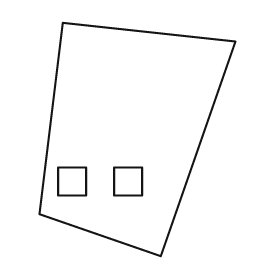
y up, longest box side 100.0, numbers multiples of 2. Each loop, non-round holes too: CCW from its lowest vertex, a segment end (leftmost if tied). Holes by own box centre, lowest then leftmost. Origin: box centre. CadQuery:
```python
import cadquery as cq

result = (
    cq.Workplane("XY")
    .moveTo(10.0, -50.0)
    .lineTo(42.0, 42.0)
    .lineTo(-32.0, 50.0)
    .lineTo(-42.0, -32.0)
    .close()
    .moveTo(-34.0, -24.0)
    .lineTo(-22.0, -24.0)
    .lineTo(-22.0, -12.0)
    .lineTo(-34.0, -12.0)
    .close()
    .moveTo(-10.0, -24.0)
    .lineTo(2.0, -24.0)
    .lineTo(2.0, -12.0)
    .lineTo(-10.0, -12.0)
    .close()
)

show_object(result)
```